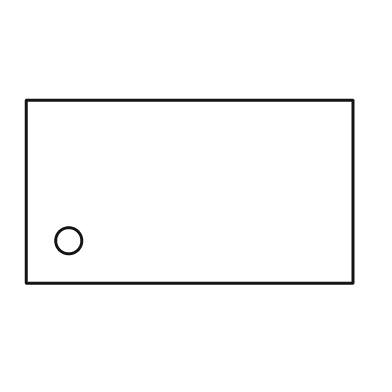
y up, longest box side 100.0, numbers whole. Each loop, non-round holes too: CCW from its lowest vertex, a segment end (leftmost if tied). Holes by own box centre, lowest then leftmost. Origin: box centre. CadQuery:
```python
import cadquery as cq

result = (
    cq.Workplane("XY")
    .moveTo(-50.0, -28.0)
    .lineTo(50.0, -28.0)
    .lineTo(50.0, 28.0)
    .lineTo(-50.0, 28.0)
    .close()
    .moveTo(-37.0, -15.0)
    .circle(4.0)
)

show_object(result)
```